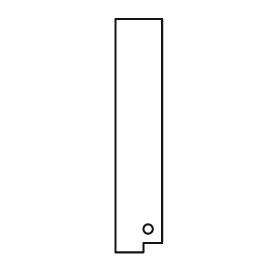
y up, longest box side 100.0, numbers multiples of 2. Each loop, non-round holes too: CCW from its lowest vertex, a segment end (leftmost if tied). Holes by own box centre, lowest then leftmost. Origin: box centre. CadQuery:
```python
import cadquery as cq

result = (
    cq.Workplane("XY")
    .moveTo(-10.0, -50.0)
    .lineTo(2.0, -50.0)
    .lineTo(2.0, -46.0)
    .lineTo(10.0, -46.0)
    .lineTo(10.0, 50.0)
    .lineTo(-10.0, 50.0)
    .close()
    .moveTo(4.0, -40.0)
    .circle(2.0)
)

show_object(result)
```